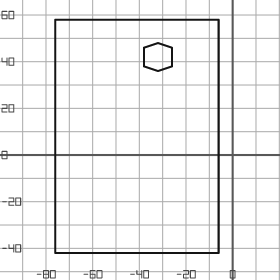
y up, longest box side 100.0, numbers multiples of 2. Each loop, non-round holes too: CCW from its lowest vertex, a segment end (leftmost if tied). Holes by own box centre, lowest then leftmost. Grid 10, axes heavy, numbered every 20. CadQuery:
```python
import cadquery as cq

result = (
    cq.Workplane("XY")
    .moveTo(-76.0, -42.0)
    .lineTo(-6.0, -42.0)
    .lineTo(-6.0, 58.0)
    .lineTo(-76.0, 58.0)
    .close()
    .moveTo(-32.0, 36.0)
    .lineTo(-26.0, 38.0)
    .lineTo(-26.0, 46.0)
    .lineTo(-32.0, 48.0)
    .lineTo(-38.0, 46.0)
    .lineTo(-38.0, 38.0)
    .close()
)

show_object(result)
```